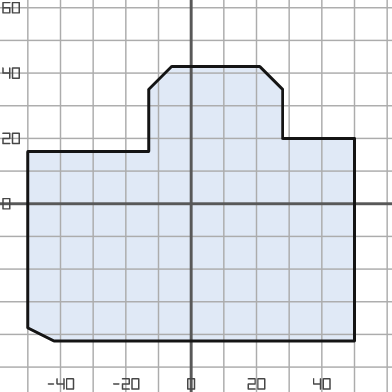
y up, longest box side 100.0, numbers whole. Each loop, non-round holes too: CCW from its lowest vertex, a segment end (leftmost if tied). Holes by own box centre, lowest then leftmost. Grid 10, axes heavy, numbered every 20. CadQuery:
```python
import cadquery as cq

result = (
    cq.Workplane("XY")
    .moveTo(-42.0, -42.0)
    .lineTo(50.0, -42.0)
    .lineTo(50.0, 20.0)
    .lineTo(28.0, 20.0)
    .lineTo(28.0, 35.0)
    .lineTo(21.0, 42.0)
    .lineTo(-6.0, 42.0)
    .lineTo(-13.0, 35.0)
    .lineTo(-13.0, 16.0)
    .lineTo(-50.0, 16.0)
    .lineTo(-50.0, -38.0)
    .close()
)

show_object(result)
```